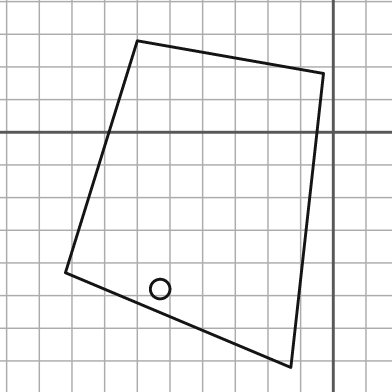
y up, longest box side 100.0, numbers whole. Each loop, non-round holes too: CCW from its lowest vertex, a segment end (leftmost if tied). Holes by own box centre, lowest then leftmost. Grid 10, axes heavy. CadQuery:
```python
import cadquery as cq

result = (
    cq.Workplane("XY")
    .moveTo(-13.0, -72.0)
    .lineTo(-3.0, 18.0)
    .lineTo(-60.0, 28.0)
    .lineTo(-82.0, -43.0)
    .close()
    .moveTo(-53.0, -48.0)
    .circle(3.0)
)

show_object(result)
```